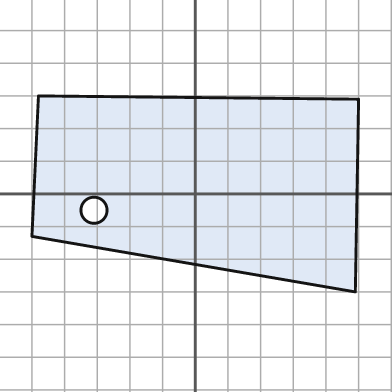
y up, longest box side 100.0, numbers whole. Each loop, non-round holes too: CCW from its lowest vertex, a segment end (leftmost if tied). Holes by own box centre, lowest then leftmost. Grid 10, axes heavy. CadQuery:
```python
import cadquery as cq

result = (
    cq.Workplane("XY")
    .moveTo(49.0, -30.0)
    .lineTo(50.0, 29.0)
    .lineTo(-48.0, 30.0)
    .lineTo(-50.0, -13.0)
    .close()
    .moveTo(-31.0, -5.0)
    .circle(4.0)
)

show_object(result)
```